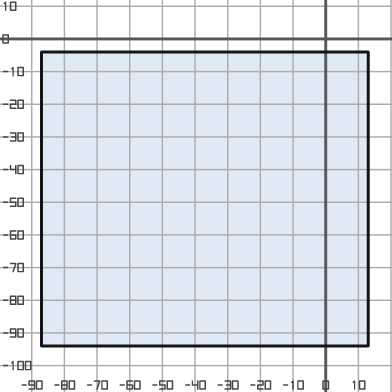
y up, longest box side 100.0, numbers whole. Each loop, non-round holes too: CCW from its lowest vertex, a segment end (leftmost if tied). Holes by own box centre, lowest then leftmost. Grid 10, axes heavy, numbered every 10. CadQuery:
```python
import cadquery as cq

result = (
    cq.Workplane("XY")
    .moveTo(-87.0, -94.0)
    .lineTo(13.0, -94.0)
    .lineTo(13.0, -4.0)
    .lineTo(-87.0, -4.0)
    .close()
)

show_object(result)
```